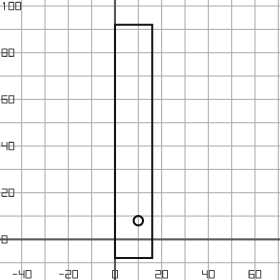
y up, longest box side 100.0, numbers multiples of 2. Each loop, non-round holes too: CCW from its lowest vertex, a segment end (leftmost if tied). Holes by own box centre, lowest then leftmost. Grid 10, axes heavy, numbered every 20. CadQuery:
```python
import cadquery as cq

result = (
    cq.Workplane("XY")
    .moveTo(0.0, -8.0)
    .lineTo(16.0, -8.0)
    .lineTo(16.0, 92.0)
    .lineTo(0.0, 92.0)
    .close()
    .moveTo(10.0, 8.0)
    .circle(2.0)
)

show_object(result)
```